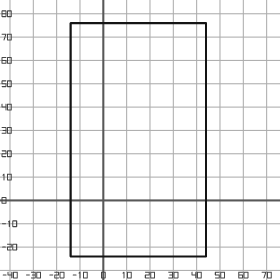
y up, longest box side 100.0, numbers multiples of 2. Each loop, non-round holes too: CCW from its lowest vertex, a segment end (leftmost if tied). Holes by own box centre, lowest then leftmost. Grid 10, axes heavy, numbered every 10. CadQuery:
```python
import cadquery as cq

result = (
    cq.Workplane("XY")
    .moveTo(-14.0, -24.0)
    .lineTo(44.0, -24.0)
    .lineTo(44.0, 76.0)
    .lineTo(-14.0, 76.0)
    .close()
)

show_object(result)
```